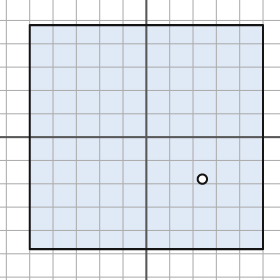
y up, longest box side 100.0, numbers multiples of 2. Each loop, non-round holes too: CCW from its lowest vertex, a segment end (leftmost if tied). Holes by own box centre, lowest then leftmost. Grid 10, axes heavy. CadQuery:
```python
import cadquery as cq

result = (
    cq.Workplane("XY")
    .moveTo(-50.0, -48.0)
    .lineTo(50.0, -48.0)
    .lineTo(50.0, 48.0)
    .lineTo(-50.0, 48.0)
    .close()
    .moveTo(24.0, -18.0)
    .circle(2.0)
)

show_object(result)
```